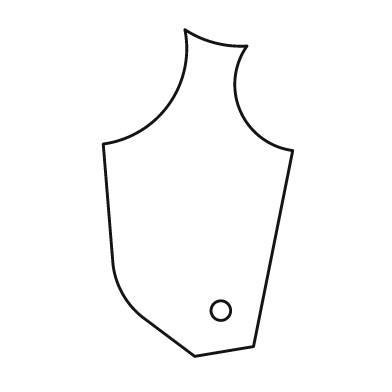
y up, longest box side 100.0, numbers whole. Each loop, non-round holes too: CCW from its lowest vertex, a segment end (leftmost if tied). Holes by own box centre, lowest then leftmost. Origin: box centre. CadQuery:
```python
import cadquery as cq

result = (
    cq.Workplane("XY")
    .moveTo(-1.0, -50.0)
    .lineTo(17.0, -47.0)
    .lineTo(29.0, 13.0)
    .threePointArc((13.0, 25.0), (15.0, 45.0))
    .threePointArc((5.0, 46.0), (-4.0, 50.0))
    .threePointArc((-9.0, 27.0), (-29.0, 15.0))
    .lineTo(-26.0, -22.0)
    .threePointArc((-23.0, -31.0), (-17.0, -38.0))
    .close()
    .moveTo(7.0, -36.0)
    .circle(3.0)
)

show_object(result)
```